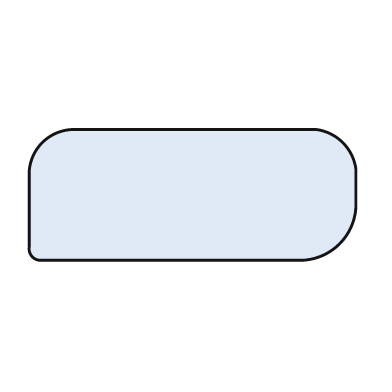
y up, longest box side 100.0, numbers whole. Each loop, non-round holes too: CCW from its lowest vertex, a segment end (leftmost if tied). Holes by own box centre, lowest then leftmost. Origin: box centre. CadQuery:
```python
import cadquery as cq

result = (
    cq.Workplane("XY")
    .moveTo(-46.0, -20.0)
    .lineTo(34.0, -20.0)
    .threePointArc((45.0, -15.0), (50.0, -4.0))
    .lineTo(50.0, 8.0)
    .threePointArc((46.0, 16.0), (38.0, 20.0))
    .lineTo(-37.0, 20.0)
    .threePointArc((-46.0, 16.0), (-50.0, 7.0))
    .lineTo(-50.0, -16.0)
    .threePointArc((-49.0, -19.0), (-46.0, -20.0))
    .close()
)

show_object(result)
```